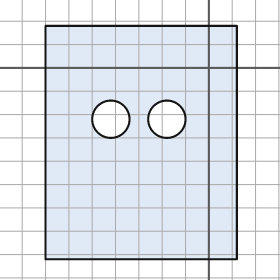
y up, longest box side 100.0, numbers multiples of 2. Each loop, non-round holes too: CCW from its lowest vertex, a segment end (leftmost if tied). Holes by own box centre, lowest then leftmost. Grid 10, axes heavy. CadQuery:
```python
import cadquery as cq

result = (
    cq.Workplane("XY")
    .moveTo(-70.0, -82.0)
    .lineTo(12.0, -82.0)
    .lineTo(12.0, 18.0)
    .lineTo(-70.0, 18.0)
    .close()
    .moveTo(-42.0, -22.0)
    .circle(8.0)
    .moveTo(-18.0, -22.0)
    .circle(8.0)
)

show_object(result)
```